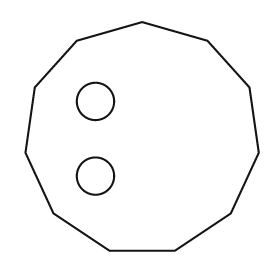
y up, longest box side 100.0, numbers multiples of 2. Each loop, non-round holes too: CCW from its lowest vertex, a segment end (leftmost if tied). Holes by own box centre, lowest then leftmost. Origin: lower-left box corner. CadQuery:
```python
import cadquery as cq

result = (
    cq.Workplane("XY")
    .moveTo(36.0, 0.0)
    .lineTo(64.0, 0.0)
    .lineTo(88.0, 16.0)
    .lineTo(100.0, 42.0)
    .lineTo(96.0, 70.0)
    .lineTo(78.0, 90.0)
    .lineTo(50.0, 98.0)
    .lineTo(22.0, 90.0)
    .lineTo(4.0, 70.0)
    .lineTo(0.0, 42.0)
    .lineTo(12.0, 16.0)
    .close()
    .moveTo(30.0, 32.0)
    .circle(8.0)
    .moveTo(30.0, 64.0)
    .circle(8.0)
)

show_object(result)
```